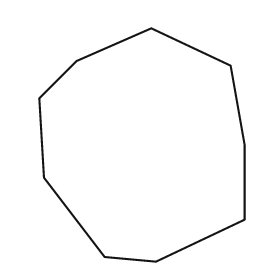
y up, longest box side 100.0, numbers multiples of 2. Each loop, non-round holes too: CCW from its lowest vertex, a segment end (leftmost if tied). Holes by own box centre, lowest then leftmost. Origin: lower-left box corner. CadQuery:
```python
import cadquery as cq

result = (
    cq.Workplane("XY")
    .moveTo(50.0, 0.0)
    .lineTo(88.0, 18.0)
    .lineTo(88.0, 50.0)
    .lineTo(82.0, 84.0)
    .lineTo(48.0, 100.0)
    .lineTo(16.0, 86.0)
    .lineTo(0.0, 70.0)
    .lineTo(2.0, 36.0)
    .lineTo(28.0, 2.0)
    .close()
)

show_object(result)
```